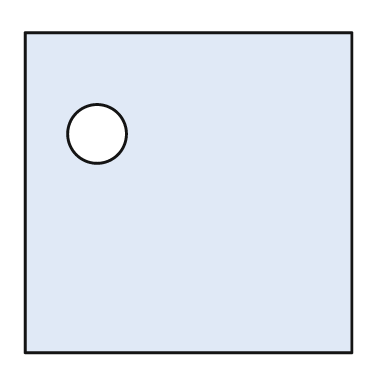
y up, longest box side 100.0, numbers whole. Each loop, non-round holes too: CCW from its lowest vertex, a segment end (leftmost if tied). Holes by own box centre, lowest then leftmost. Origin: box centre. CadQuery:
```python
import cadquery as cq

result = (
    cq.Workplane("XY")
    .moveTo(-50.0, -49.0)
    .lineTo(50.0, -49.0)
    .lineTo(50.0, 49.0)
    .lineTo(-50.0, 49.0)
    .close()
    .moveTo(-28.0, 18.0)
    .circle(9.0)
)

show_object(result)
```